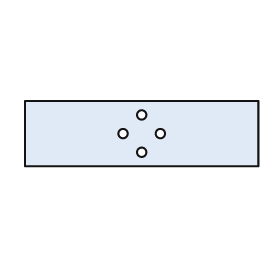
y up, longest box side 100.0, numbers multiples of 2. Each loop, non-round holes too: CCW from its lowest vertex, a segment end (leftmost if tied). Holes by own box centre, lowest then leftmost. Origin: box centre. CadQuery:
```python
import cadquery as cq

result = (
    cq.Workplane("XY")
    .moveTo(-50.0, -14.0)
    .lineTo(50.0, -14.0)
    .lineTo(50.0, 14.0)
    .lineTo(-50.0, 14.0)
    .close()
    .moveTo(0.0, -8.0)
    .circle(2.0)
    .moveTo(-8.0, 0.0)
    .circle(2.0)
    .moveTo(8.0, 0.0)
    .circle(2.0)
    .moveTo(0.0, 8.0)
    .circle(2.0)
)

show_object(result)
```